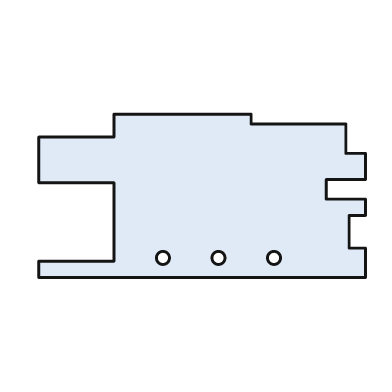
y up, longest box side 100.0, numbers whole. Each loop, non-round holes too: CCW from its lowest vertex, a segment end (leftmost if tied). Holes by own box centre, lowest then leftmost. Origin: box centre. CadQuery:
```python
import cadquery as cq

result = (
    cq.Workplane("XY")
    .moveTo(-50.0, -25.0)
    .lineTo(50.0, -25.0)
    .lineTo(50.0, -16.0)
    .lineTo(45.0, -16.0)
    .lineTo(45.0, -6.0)
    .lineTo(50.0, -6.0)
    .lineTo(50.0, -1.0)
    .lineTo(38.0, -1.0)
    .lineTo(38.0, 5.0)
    .lineTo(50.0, 5.0)
    .lineTo(50.0, 13.0)
    .lineTo(44.0, 13.0)
    .lineTo(44.0, 22.0)
    .lineTo(15.0, 22.0)
    .lineTo(15.0, 25.0)
    .lineTo(-27.0, 25.0)
    .lineTo(-27.0, 18.0)
    .lineTo(-50.0, 18.0)
    .lineTo(-50.0, 4.0)
    .lineTo(-27.0, 4.0)
    .lineTo(-27.0, -20.0)
    .lineTo(-50.0, -20.0)
    .close()
    .moveTo(-12.0, -19.0)
    .circle(2.0)
    .moveTo(5.0, -19.0)
    .circle(2.0)
    .moveTo(22.0, -19.0)
    .circle(2.0)
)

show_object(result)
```